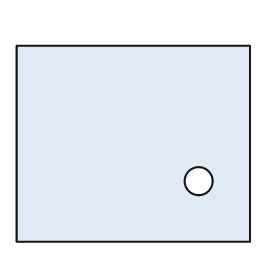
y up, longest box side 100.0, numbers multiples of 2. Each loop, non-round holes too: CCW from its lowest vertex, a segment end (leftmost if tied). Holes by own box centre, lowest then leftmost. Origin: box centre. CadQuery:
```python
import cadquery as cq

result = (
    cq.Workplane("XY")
    .moveTo(-50.0, -42.0)
    .lineTo(50.0, -42.0)
    .lineTo(50.0, 42.0)
    .lineTo(-50.0, 42.0)
    .close()
    .moveTo(28.0, -16.0)
    .circle(6.0)
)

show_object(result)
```